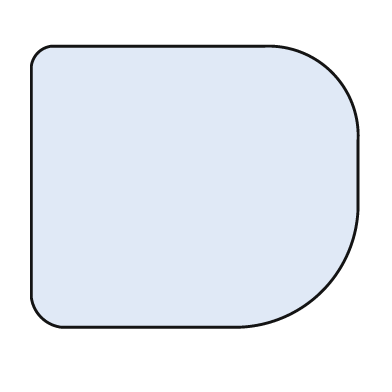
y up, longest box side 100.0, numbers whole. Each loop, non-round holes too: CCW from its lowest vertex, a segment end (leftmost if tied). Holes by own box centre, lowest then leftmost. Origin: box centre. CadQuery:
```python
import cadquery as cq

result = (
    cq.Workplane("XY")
    .moveTo(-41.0, -43.0)
    .lineTo(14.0, -43.0)
    .threePointArc((39.0, -32.0), (50.0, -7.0))
    .lineTo(50.0, 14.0)
    .threePointArc((42.0, 35.0), (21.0, 43.0))
    .lineTo(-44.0, 43.0)
    .threePointArc((-48.0, 41.0), (-50.0, 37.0))
    .lineTo(-50.0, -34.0)
    .threePointArc((-47.0, -40.0), (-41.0, -43.0))
    .close()
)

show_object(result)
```